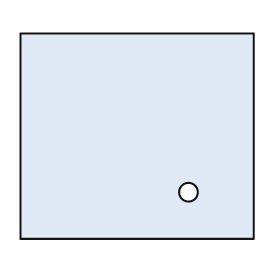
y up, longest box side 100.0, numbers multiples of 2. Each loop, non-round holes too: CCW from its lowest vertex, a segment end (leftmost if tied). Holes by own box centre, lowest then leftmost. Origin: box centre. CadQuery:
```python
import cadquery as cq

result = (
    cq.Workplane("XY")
    .moveTo(-50.0, -44.0)
    .lineTo(50.0, -44.0)
    .lineTo(50.0, 44.0)
    .lineTo(-50.0, 44.0)
    .close()
    .moveTo(22.0, -24.0)
    .circle(4.0)
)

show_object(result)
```